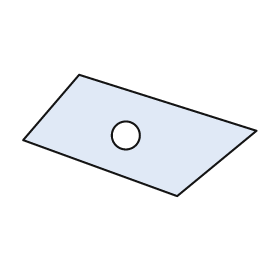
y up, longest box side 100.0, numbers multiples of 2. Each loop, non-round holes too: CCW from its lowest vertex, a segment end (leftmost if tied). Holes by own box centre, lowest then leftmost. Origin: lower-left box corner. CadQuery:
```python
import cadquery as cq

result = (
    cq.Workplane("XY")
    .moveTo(66.0, 0.0)
    .lineTo(100.0, 28.0)
    .lineTo(24.0, 52.0)
    .lineTo(0.0, 24.0)
    .close()
    .moveTo(44.0, 26.0)
    .circle(6.0)
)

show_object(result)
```